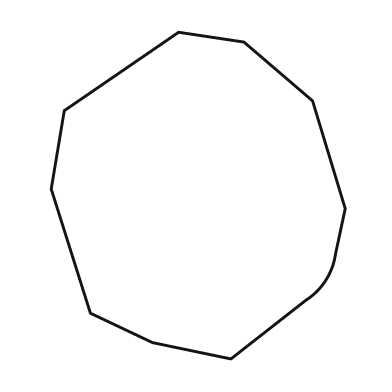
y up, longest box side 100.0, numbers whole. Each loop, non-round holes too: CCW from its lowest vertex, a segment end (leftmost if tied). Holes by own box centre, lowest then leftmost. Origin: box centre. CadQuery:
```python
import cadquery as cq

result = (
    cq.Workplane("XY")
    .moveTo(10.0, -50.0)
    .lineTo(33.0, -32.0)
    .threePointArc((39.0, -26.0), (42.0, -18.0))
    .lineTo(45.0, -4.0)
    .lineTo(35.0, 29.0)
    .lineTo(14.0, 47.0)
    .lineTo(-6.0, 50.0)
    .lineTo(-41.0, 26.0)
    .lineTo(-45.0, 2.0)
    .lineTo(-33.0, -36.0)
    .lineTo(-14.0, -45.0)
    .close()
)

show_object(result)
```